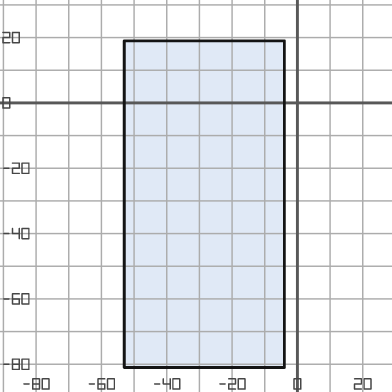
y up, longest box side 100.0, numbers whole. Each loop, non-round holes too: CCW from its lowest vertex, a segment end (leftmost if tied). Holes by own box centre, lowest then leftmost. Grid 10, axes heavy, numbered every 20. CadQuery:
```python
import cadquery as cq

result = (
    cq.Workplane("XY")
    .moveTo(-53.0, -81.0)
    .lineTo(-4.0, -81.0)
    .lineTo(-4.0, 19.0)
    .lineTo(-53.0, 19.0)
    .close()
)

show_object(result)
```